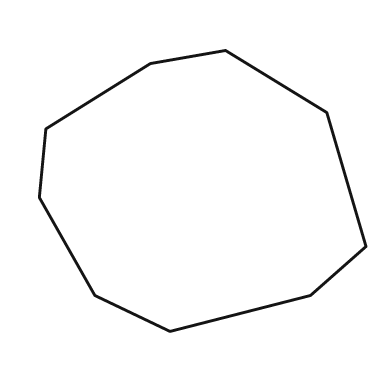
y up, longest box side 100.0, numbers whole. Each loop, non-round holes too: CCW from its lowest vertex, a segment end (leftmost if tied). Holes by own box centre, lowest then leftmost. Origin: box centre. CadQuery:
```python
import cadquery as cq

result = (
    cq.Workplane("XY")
    .moveTo(-10.0, -43.0)
    .lineTo(33.0, -32.0)
    .lineTo(50.0, -17.0)
    .lineTo(38.0, 24.0)
    .lineTo(7.0, 43.0)
    .lineTo(-16.0, 39.0)
    .lineTo(-48.0, 19.0)
    .lineTo(-50.0, -2.0)
    .lineTo(-33.0, -32.0)
    .close()
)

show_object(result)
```